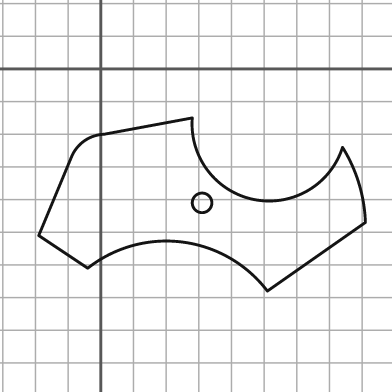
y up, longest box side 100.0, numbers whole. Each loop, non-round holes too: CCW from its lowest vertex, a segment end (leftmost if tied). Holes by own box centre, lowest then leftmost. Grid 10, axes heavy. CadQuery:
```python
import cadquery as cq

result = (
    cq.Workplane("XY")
    .moveTo(51.0, -68.0)
    .lineTo(81.0, -47.0)
    .threePointArc((79.0, -35.0), (74.0, -24.0))
    .threePointArc((47.0, -40.0), (28.0, -15.0))
    .lineTo(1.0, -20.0)
    .threePointArc((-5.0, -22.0), (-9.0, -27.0))
    .lineTo(-19.0, -51.0)
    .lineTo(-4.0, -61.0)
    .threePointArc((25.0, -53.0), (51.0, -68.0))
    .close()
    .moveTo(31.0, -41.0)
    .circle(3.0)
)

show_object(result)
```